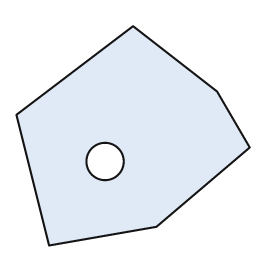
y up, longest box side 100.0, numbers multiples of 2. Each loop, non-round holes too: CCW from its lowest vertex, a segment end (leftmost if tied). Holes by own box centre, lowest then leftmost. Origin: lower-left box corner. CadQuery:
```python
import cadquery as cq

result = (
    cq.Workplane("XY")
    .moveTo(14.0, 0.0)
    .lineTo(60.0, 8.0)
    .lineTo(100.0, 42.0)
    .lineTo(86.0, 66.0)
    .lineTo(50.0, 94.0)
    .lineTo(0.0, 56.0)
    .close()
    .moveTo(38.0, 36.0)
    .circle(8.0)
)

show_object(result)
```